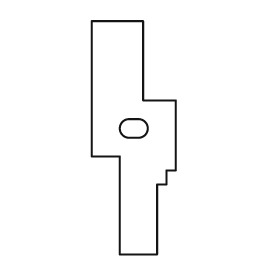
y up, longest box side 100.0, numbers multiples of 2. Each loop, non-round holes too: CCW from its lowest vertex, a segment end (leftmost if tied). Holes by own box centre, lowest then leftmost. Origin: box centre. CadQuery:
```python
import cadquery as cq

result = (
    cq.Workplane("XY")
    .moveTo(-6.0, -50.0)
    .lineTo(10.0, -50.0)
    .lineTo(10.0, -20.0)
    .lineTo(14.0, -20.0)
    .lineTo(14.0, -14.0)
    .lineTo(18.0, -14.0)
    .lineTo(18.0, 16.0)
    .lineTo(4.0, 16.0)
    .lineTo(4.0, 50.0)
    .lineTo(-18.0, 50.0)
    .lineTo(-18.0, -8.0)
    .lineTo(-6.0, -8.0)
    .close()
    .moveTo(-2.0, 0.0)
    .lineTo(2.0, 0.0)
    .threePointArc((6.0, 4.0), (2.0, 8.0))
    .lineTo(-2.0, 8.0)
    .threePointArc((-6.0, 4.0), (-2.0, 0.0))
    .close()
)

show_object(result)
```